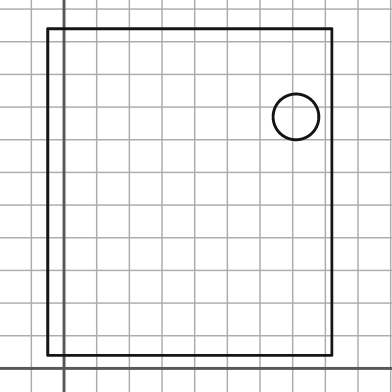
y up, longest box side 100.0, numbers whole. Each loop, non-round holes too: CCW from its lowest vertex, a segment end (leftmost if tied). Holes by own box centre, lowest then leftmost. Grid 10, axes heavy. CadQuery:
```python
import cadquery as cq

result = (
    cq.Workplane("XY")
    .moveTo(-5.0, 4.0)
    .lineTo(82.0, 4.0)
    .lineTo(82.0, 104.0)
    .lineTo(-5.0, 104.0)
    .close()
    .moveTo(71.0, 77.0)
    .circle(7.0)
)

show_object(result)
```